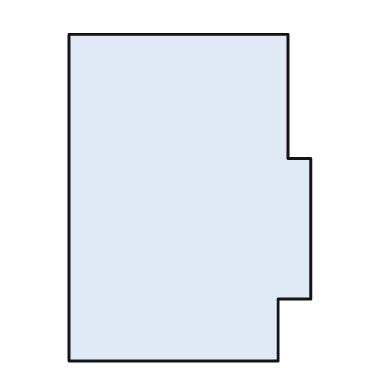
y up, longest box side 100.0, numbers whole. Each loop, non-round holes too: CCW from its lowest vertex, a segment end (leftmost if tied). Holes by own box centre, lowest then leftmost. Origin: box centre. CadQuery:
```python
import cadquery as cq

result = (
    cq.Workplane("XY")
    .moveTo(-37.0, -50.0)
    .lineTo(27.0, -50.0)
    .lineTo(27.0, -31.0)
    .lineTo(37.0, -31.0)
    .lineTo(37.0, 12.0)
    .lineTo(30.0, 12.0)
    .lineTo(30.0, 50.0)
    .lineTo(-37.0, 50.0)
    .close()
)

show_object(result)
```